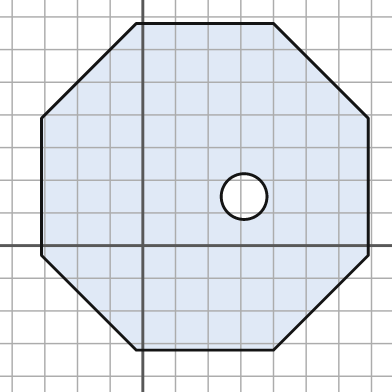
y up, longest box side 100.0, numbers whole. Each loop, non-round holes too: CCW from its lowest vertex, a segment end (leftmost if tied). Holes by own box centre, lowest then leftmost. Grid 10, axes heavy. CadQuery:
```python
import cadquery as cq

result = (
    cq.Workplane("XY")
    .moveTo(-2.0, -32.0)
    .lineTo(40.0, -32.0)
    .lineTo(69.0, -3.0)
    .lineTo(69.0, 39.0)
    .lineTo(40.0, 68.0)
    .lineTo(-2.0, 68.0)
    .lineTo(-31.0, 39.0)
    .lineTo(-31.0, -3.0)
    .close()
    .moveTo(31.0, 15.0)
    .circle(7.0)
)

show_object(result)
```